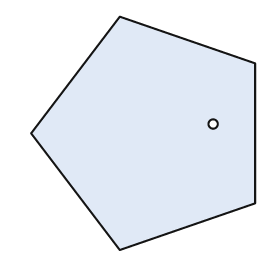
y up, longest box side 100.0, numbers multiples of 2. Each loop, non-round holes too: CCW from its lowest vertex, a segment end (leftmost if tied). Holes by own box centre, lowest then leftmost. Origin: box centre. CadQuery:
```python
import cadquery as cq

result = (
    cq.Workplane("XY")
    .moveTo(-10.0, -50.0)
    .lineTo(48.0, -30.0)
    .lineTo(48.0, 30.0)
    .lineTo(-10.0, 50.0)
    .lineTo(-48.0, 0.0)
    .close()
    .moveTo(30.0, 4.0)
    .circle(2.0)
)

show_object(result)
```